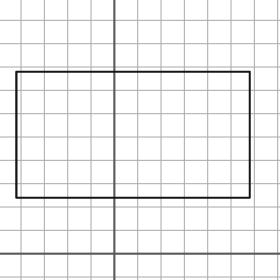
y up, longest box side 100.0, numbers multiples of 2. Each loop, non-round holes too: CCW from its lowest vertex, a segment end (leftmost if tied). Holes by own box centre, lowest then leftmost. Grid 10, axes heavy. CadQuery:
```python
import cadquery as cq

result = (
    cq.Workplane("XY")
    .moveTo(-42.0, 24.0)
    .lineTo(58.0, 24.0)
    .lineTo(58.0, 78.0)
    .lineTo(-42.0, 78.0)
    .close()
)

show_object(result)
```